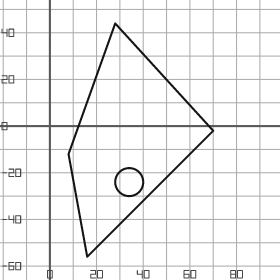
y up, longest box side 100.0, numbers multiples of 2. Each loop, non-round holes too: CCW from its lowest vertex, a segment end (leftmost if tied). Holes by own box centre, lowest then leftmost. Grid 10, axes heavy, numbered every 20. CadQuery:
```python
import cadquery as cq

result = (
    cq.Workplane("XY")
    .moveTo(16.0, -56.0)
    .lineTo(70.0, -2.0)
    .lineTo(28.0, 44.0)
    .lineTo(8.0, -12.0)
    .close()
    .moveTo(34.0, -24.0)
    .circle(6.0)
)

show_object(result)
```